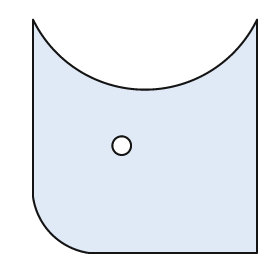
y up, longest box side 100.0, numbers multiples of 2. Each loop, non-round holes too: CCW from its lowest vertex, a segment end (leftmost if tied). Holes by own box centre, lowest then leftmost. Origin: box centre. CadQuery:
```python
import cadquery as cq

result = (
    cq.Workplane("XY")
    .moveTo(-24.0, -50.0)
    .lineTo(48.0, -50.0)
    .lineTo(48.0, 50.0)
    .threePointArc((0.0, 20.0), (-48.0, 50.0))
    .lineTo(-48.0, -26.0)
    .threePointArc((-40.0, -42.0), (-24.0, -50.0))
    .close()
    .moveTo(-10.0, -4.0)
    .circle(4.0)
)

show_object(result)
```